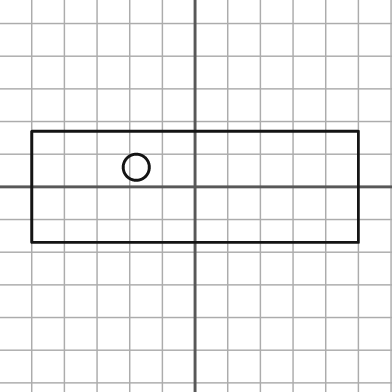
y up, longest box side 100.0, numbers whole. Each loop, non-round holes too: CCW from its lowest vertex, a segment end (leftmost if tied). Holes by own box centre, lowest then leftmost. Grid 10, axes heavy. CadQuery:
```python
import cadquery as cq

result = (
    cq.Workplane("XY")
    .moveTo(-50.0, -17.0)
    .lineTo(50.0, -17.0)
    .lineTo(50.0, 17.0)
    .lineTo(-50.0, 17.0)
    .close()
    .moveTo(-18.0, 6.0)
    .circle(4.0)
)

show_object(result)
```